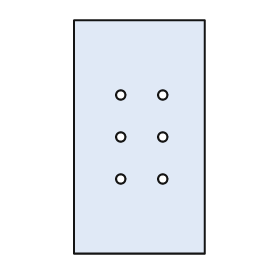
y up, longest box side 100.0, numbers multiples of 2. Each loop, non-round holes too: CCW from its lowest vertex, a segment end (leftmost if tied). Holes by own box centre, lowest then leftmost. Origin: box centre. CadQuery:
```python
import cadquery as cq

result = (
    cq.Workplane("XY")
    .moveTo(-28.0, -50.0)
    .lineTo(28.0, -50.0)
    .lineTo(28.0, 50.0)
    .lineTo(-28.0, 50.0)
    .close()
    .moveTo(-8.0, -18.0)
    .circle(2.0)
    .moveTo(10.0, -18.0)
    .circle(2.0)
    .moveTo(-8.0, 0.0)
    .circle(2.0)
    .moveTo(10.0, 0.0)
    .circle(2.0)
    .moveTo(-8.0, 18.0)
    .circle(2.0)
    .moveTo(10.0, 18.0)
    .circle(2.0)
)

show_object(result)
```